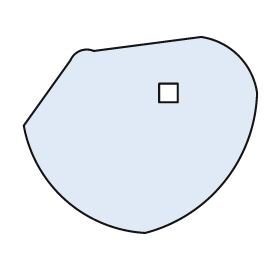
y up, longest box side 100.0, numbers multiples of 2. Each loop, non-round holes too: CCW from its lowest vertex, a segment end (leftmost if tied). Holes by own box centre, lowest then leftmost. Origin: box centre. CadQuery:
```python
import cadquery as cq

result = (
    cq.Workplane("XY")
    .moveTo(2.0, -42.0)
    .threePointArc((36.0, -20.0), (50.0, 18.0))
    .threePointArc((42.0, 34.0), (26.0, 42.0))
    .lineTo(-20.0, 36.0)
    .threePointArc((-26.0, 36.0), (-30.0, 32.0))
    .lineTo(-50.0, 4.0)
    .threePointArc((-32.0, -28.0), (2.0, -42.0))
    .close()
    .moveTo(8.0, 14.0)
    .lineTo(16.0, 14.0)
    .lineTo(16.0, 22.0)
    .lineTo(8.0, 22.0)
    .close()
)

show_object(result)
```